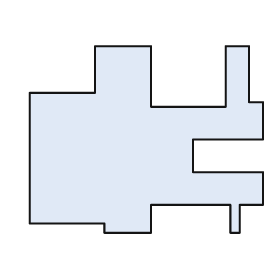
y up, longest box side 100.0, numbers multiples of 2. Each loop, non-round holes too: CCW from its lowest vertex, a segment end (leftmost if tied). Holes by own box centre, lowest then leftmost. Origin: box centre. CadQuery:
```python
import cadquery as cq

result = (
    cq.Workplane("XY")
    .moveTo(-18.0, -40.0)
    .lineTo(2.0, -40.0)
    .lineTo(2.0, -28.0)
    .lineTo(36.0, -28.0)
    .lineTo(36.0, -40.0)
    .lineTo(40.0, -40.0)
    .lineTo(40.0, -28.0)
    .lineTo(50.0, -28.0)
    .lineTo(50.0, -14.0)
    .lineTo(20.0, -14.0)
    .lineTo(20.0, 0.0)
    .lineTo(50.0, 0.0)
    .lineTo(50.0, 16.0)
    .lineTo(44.0, 16.0)
    .lineTo(44.0, 40.0)
    .lineTo(34.0, 40.0)
    .lineTo(34.0, 14.0)
    .lineTo(2.0, 14.0)
    .lineTo(2.0, 40.0)
    .lineTo(-22.0, 40.0)
    .lineTo(-22.0, 20.0)
    .lineTo(-50.0, 20.0)
    .lineTo(-50.0, -36.0)
    .lineTo(-18.0, -36.0)
    .close()
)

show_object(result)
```